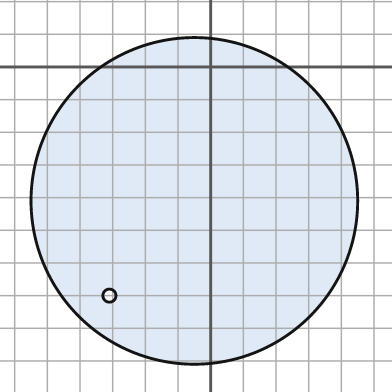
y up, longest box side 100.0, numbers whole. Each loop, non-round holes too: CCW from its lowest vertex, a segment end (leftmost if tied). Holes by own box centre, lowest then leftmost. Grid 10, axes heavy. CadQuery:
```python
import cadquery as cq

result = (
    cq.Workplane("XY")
    .moveTo(-5.0, -41.0)
    .circle(50.0)
    .moveTo(-31.0, -70.0)
    .circle(2.0)
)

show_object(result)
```